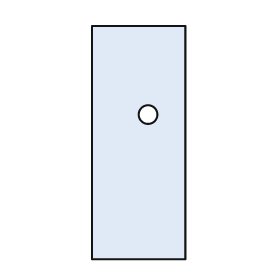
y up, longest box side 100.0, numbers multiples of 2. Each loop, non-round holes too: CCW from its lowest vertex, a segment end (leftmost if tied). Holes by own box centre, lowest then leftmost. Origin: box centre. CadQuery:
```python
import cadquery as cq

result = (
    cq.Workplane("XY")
    .moveTo(-20.0, -50.0)
    .lineTo(20.0, -50.0)
    .lineTo(20.0, 50.0)
    .lineTo(-20.0, 50.0)
    .close()
    .moveTo(4.0, 12.0)
    .circle(4.0)
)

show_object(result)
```